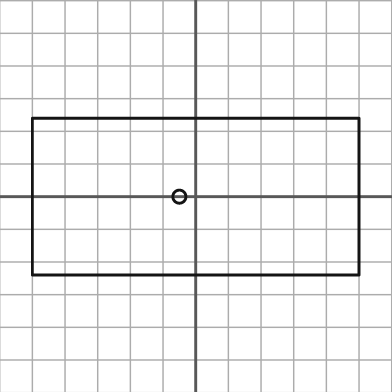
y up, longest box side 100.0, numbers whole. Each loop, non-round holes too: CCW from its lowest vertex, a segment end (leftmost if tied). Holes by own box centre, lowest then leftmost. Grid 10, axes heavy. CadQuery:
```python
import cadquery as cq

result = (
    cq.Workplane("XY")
    .moveTo(-50.0, -24.0)
    .lineTo(50.0, -24.0)
    .lineTo(50.0, 24.0)
    .lineTo(-50.0, 24.0)
    .close()
    .moveTo(-5.0, 0.0)
    .circle(2.0)
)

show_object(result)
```